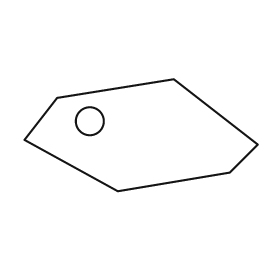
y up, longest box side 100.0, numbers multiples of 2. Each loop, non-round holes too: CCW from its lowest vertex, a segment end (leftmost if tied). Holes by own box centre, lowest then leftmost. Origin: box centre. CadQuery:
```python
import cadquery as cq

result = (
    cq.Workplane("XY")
    .moveTo(-10.0, -24.0)
    .lineTo(38.0, -16.0)
    .lineTo(50.0, -4.0)
    .lineTo(14.0, 24.0)
    .lineTo(-36.0, 16.0)
    .lineTo(-50.0, -2.0)
    .close()
    .moveTo(-22.0, 6.0)
    .circle(6.0)
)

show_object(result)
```